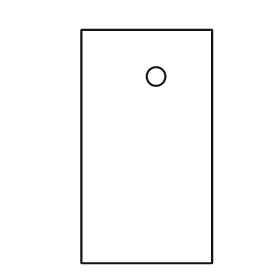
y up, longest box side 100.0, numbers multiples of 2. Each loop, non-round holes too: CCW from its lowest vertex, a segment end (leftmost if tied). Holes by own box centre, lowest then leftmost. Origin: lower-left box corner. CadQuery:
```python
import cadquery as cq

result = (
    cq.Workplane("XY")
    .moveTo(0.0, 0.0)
    .lineTo(56.0, 0.0)
    .lineTo(56.0, 100.0)
    .lineTo(0.0, 100.0)
    .close()
    .moveTo(32.0, 80.0)
    .circle(4.0)
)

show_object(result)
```